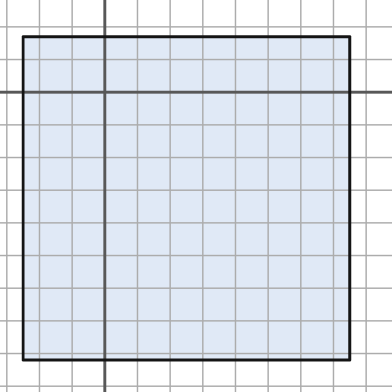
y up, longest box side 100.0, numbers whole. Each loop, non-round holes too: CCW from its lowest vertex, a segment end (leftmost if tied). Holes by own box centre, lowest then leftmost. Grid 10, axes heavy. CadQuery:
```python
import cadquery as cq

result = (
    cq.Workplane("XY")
    .moveTo(-25.0, -82.0)
    .lineTo(75.0, -82.0)
    .lineTo(75.0, 17.0)
    .lineTo(-25.0, 17.0)
    .close()
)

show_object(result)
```